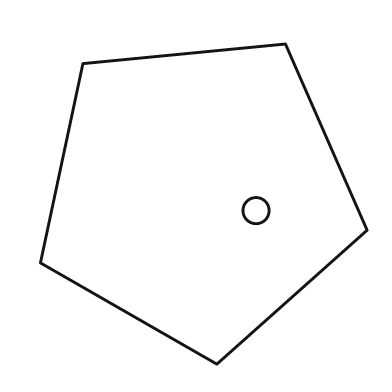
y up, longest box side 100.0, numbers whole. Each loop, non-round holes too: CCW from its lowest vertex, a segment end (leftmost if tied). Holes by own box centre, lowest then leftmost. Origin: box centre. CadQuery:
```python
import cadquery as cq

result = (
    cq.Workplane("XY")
    .moveTo(4.0, -49.0)
    .lineTo(50.0, -8.0)
    .lineTo(25.0, 49.0)
    .lineTo(-37.0, 43.0)
    .lineTo(-50.0, -18.0)
    .close()
    .moveTo(16.0, -2.0)
    .circle(4.0)
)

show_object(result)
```